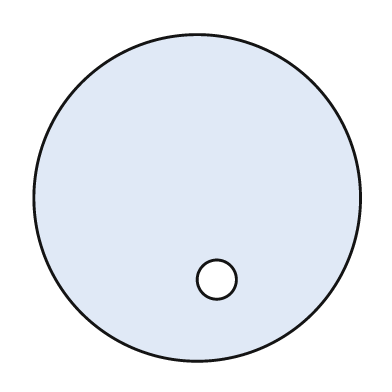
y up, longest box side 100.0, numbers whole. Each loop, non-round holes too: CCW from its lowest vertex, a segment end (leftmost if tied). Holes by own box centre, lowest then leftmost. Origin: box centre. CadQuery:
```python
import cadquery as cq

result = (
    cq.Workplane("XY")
    .moveTo(0.0, 0.0)
    .circle(50.0)
    .moveTo(6.0, -25.0)
    .circle(6.0)
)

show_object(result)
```